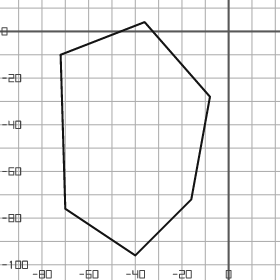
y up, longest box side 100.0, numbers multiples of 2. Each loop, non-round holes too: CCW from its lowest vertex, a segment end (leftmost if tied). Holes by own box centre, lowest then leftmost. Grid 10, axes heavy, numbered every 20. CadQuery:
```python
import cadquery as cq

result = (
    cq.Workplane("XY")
    .moveTo(-40.0, -96.0)
    .lineTo(-16.0, -72.0)
    .lineTo(-8.0, -28.0)
    .lineTo(-36.0, 4.0)
    .lineTo(-72.0, -10.0)
    .lineTo(-70.0, -76.0)
    .close()
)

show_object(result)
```